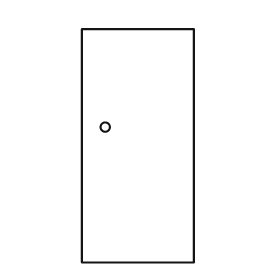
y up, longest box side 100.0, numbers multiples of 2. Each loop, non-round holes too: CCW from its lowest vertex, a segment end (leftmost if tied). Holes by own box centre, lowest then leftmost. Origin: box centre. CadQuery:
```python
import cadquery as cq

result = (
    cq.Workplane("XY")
    .moveTo(-24.0, -50.0)
    .lineTo(24.0, -50.0)
    .lineTo(24.0, 50.0)
    .lineTo(-24.0, 50.0)
    .close()
    .moveTo(-14.0, 8.0)
    .circle(2.0)
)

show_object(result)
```